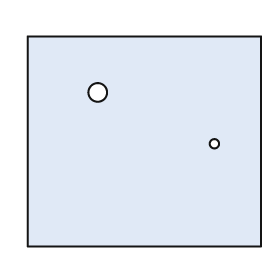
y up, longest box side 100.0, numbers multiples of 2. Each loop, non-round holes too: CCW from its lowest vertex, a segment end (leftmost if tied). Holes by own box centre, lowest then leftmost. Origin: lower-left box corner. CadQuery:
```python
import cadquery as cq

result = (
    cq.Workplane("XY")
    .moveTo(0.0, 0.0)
    .lineTo(100.0, 0.0)
    .lineTo(100.0, 90.0)
    .lineTo(0.0, 90.0)
    .close()
    .moveTo(80.0, 44.0)
    .circle(2.0)
    .moveTo(30.0, 66.0)
    .circle(4.0)
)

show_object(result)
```